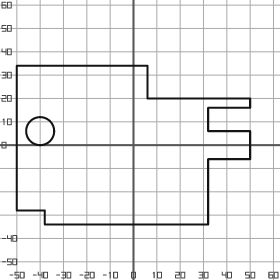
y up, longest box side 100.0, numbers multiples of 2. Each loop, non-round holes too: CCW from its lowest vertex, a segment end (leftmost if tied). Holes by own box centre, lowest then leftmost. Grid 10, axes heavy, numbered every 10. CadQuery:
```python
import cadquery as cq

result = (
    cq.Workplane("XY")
    .moveTo(-38.0, -34.0)
    .lineTo(32.0, -34.0)
    .lineTo(32.0, -6.0)
    .lineTo(50.0, -6.0)
    .lineTo(50.0, 6.0)
    .lineTo(32.0, 6.0)
    .lineTo(32.0, 16.0)
    .lineTo(50.0, 16.0)
    .lineTo(50.0, 20.0)
    .lineTo(6.0, 20.0)
    .lineTo(6.0, 34.0)
    .lineTo(-50.0, 34.0)
    .lineTo(-50.0, -28.0)
    .lineTo(-38.0, -28.0)
    .close()
    .moveTo(-40.0, 6.0)
    .circle(6.0)
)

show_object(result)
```